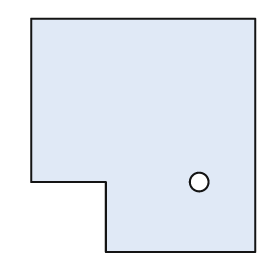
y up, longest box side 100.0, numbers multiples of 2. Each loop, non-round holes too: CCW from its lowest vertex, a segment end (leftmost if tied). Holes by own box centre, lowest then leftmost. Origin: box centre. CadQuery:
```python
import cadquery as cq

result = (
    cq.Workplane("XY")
    .moveTo(-16.0, -50.0)
    .lineTo(48.0, -50.0)
    .lineTo(48.0, 50.0)
    .lineTo(-48.0, 50.0)
    .lineTo(-48.0, -20.0)
    .lineTo(-16.0, -20.0)
    .close()
    .moveTo(24.0, -20.0)
    .circle(4.0)
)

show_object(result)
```